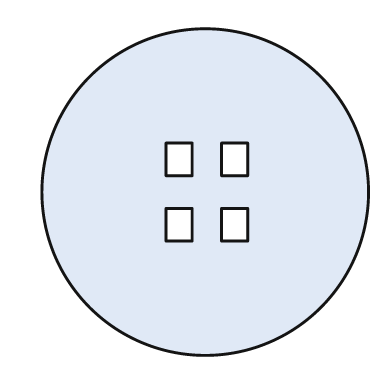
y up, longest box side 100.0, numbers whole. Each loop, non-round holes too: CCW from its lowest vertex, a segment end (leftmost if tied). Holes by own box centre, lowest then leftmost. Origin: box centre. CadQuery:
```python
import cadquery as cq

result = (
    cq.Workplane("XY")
    .moveTo(0.0, 0.0)
    .circle(50.0)
    .moveTo(-12.0, -15.0)
    .lineTo(-4.0, -15.0)
    .lineTo(-4.0, -5.0)
    .lineTo(-12.0, -5.0)
    .close()
    .moveTo(5.0, -15.0)
    .lineTo(13.0, -15.0)
    .lineTo(13.0, -5.0)
    .lineTo(5.0, -5.0)
    .close()
    .moveTo(-12.0, 5.0)
    .lineTo(-4.0, 5.0)
    .lineTo(-4.0, 15.0)
    .lineTo(-12.0, 15.0)
    .close()
    .moveTo(5.0, 5.0)
    .lineTo(13.0, 5.0)
    .lineTo(13.0, 15.0)
    .lineTo(5.0, 15.0)
    .close()
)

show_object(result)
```